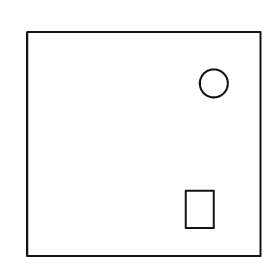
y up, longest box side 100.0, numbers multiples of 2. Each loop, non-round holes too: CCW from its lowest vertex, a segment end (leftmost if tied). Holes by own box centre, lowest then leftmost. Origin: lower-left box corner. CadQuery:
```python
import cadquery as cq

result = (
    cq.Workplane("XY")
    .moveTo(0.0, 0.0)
    .lineTo(100.0, 0.0)
    .lineTo(100.0, 96.0)
    .lineTo(0.0, 96.0)
    .close()
    .moveTo(68.0, 12.0)
    .lineTo(80.0, 12.0)
    .lineTo(80.0, 28.0)
    .lineTo(68.0, 28.0)
    .close()
    .moveTo(80.0, 74.0)
    .circle(6.0)
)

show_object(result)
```